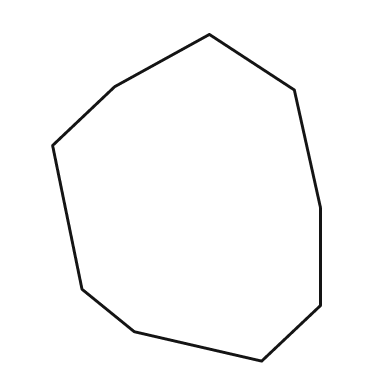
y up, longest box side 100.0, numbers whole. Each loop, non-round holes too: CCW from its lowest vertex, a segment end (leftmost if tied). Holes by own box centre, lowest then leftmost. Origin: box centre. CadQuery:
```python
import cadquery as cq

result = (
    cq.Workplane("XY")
    .moveTo(23.0, -50.0)
    .lineTo(41.0, -33.0)
    .lineTo(41.0, -3.0)
    .lineTo(33.0, 33.0)
    .lineTo(7.0, 50.0)
    .lineTo(-22.0, 34.0)
    .lineTo(-41.0, 16.0)
    .lineTo(-32.0, -28.0)
    .lineTo(-16.0, -41.0)
    .close()
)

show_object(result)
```